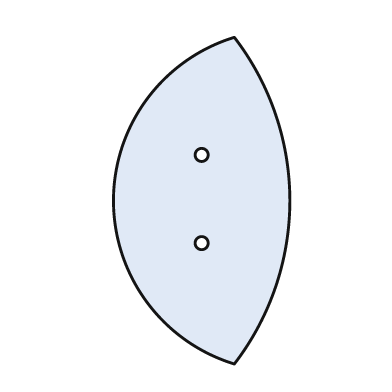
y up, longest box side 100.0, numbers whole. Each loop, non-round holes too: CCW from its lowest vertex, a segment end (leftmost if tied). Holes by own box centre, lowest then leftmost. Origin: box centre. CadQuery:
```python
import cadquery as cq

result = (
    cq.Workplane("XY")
    .moveTo(10.0, -50.0)
    .threePointArc((27.0, 0.0), (10.0, 50.0))
    .threePointArc((-27.0, 0.0), (10.0, -50.0))
    .close()
    .moveTo(0.0, -13.0)
    .circle(2.0)
    .moveTo(0.0, 14.0)
    .circle(2.0)
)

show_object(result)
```